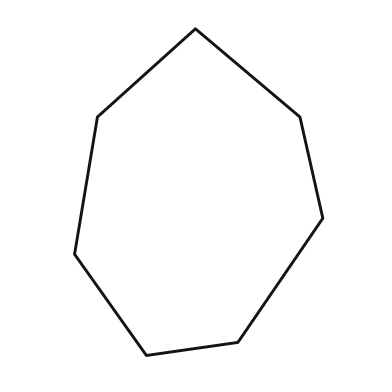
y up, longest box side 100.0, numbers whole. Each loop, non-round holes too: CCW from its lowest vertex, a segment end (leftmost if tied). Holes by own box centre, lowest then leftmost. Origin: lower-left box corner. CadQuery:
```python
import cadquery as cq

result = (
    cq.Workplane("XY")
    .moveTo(22.0, 0.0)
    .lineTo(50.0, 4.0)
    .lineTo(76.0, 42.0)
    .lineTo(69.0, 73.0)
    .lineTo(37.0, 100.0)
    .lineTo(7.0, 73.0)
    .lineTo(0.0, 31.0)
    .close()
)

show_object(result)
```